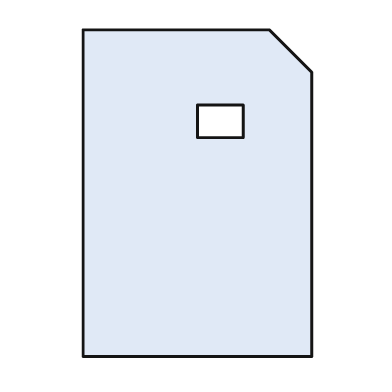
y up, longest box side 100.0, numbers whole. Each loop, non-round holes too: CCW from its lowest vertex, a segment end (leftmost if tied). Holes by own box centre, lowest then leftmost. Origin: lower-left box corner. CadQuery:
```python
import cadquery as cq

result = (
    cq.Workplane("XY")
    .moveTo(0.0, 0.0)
    .lineTo(70.0, 0.0)
    .lineTo(70.0, 87.0)
    .lineTo(57.0, 100.0)
    .lineTo(0.0, 100.0)
    .close()
    .moveTo(35.0, 67.0)
    .lineTo(49.0, 67.0)
    .lineTo(49.0, 77.0)
    .lineTo(35.0, 77.0)
    .close()
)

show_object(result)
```